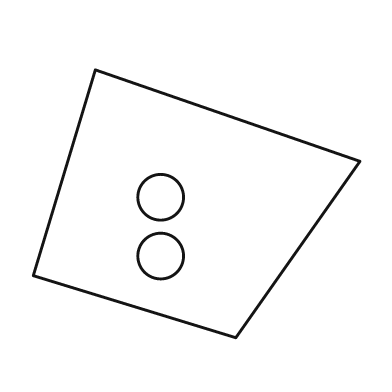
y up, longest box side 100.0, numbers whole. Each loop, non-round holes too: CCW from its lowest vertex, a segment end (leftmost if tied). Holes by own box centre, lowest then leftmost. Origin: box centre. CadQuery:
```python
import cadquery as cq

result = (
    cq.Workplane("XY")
    .moveTo(12.0, -41.0)
    .lineTo(50.0, 13.0)
    .lineTo(-31.0, 41.0)
    .lineTo(-50.0, -22.0)
    .close()
    .moveTo(-11.0, -16.0)
    .circle(7.0)
    .moveTo(-11.0, 2.0)
    .circle(7.0)
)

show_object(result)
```